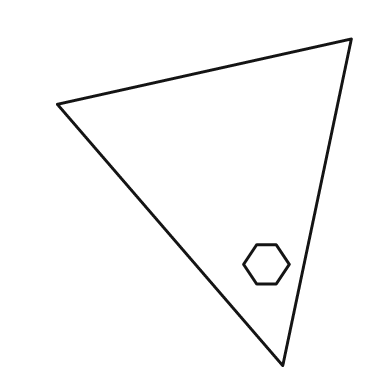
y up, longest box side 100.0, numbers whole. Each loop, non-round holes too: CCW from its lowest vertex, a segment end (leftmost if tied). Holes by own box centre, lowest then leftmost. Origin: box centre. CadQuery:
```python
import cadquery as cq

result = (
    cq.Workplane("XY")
    .moveTo(24.0, -50.0)
    .lineTo(45.0, 50.0)
    .lineTo(-45.0, 30.0)
    .close()
    .moveTo(16.0, -25.0)
    .lineTo(22.0, -25.0)
    .lineTo(26.0, -19.0)
    .lineTo(22.0, -13.0)
    .lineTo(16.0, -13.0)
    .lineTo(12.0, -19.0)
    .close()
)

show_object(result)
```